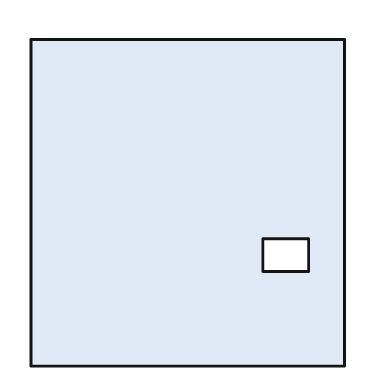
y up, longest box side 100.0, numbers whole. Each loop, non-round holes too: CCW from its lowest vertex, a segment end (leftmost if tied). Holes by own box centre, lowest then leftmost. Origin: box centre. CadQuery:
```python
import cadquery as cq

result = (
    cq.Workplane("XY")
    .moveTo(-48.0, -50.0)
    .lineTo(48.0, -50.0)
    .lineTo(48.0, 50.0)
    .lineTo(-48.0, 50.0)
    .close()
    .moveTo(23.0, -21.0)
    .lineTo(37.0, -21.0)
    .lineTo(37.0, -11.0)
    .lineTo(23.0, -11.0)
    .close()
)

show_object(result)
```